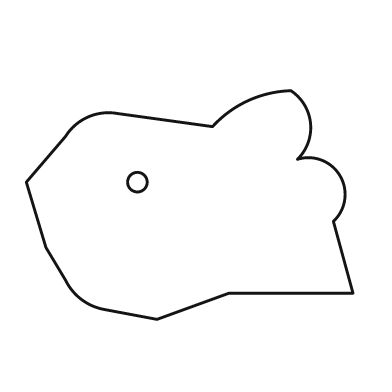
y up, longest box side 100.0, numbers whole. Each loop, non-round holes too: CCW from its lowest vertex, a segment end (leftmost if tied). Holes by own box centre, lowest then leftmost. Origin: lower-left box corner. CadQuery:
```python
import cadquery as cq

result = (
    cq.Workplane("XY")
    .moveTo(40.0, 0.0)
    .lineTo(62.0, 8.0)
    .lineTo(100.0, 8.0)
    .lineTo(94.0, 30.0)
    .threePointArc((96.0, 44.0), (83.0, 49.0))
    .threePointArc((87.0, 60.0), (81.0, 70.0))
    .threePointArc((68.0, 67.0), (57.0, 59.0))
    .lineTo(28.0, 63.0)
    .threePointArc((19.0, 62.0), (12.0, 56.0))
    .lineTo(0.0, 42.0)
    .lineTo(6.0, 22.0)
    .lineTo(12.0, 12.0)
    .threePointArc((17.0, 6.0), (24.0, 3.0))
    .close()
    .moveTo(34.0, 42.0)
    .circle(3.0)
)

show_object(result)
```